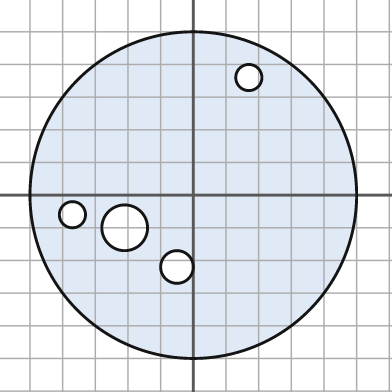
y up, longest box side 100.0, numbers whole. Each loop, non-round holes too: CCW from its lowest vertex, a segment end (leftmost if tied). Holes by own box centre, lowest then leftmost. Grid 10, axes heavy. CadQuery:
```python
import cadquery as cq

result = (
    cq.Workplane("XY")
    .moveTo(0.0, 0.0)
    .circle(50.0)
    .moveTo(-5.0, -22.0)
    .circle(5.0)
    .moveTo(-21.0, -10.0)
    .circle(7.0)
    .moveTo(-37.0, -6.0)
    .circle(4.0)
    .moveTo(17.0, 36.0)
    .circle(4.0)
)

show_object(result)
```